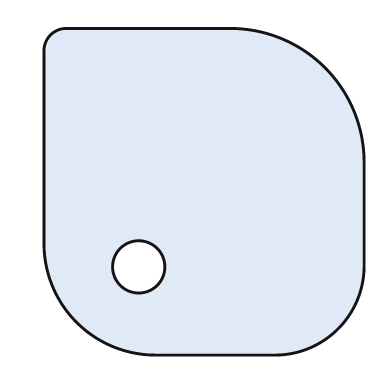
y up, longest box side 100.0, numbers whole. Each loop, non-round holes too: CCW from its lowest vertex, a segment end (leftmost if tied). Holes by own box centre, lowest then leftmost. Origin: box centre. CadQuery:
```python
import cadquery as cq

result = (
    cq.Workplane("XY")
    .moveTo(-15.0, -50.0)
    .lineTo(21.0, -50.0)
    .threePointArc((41.0, -42.0), (49.0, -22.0))
    .lineTo(49.0, 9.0)
    .threePointArc((37.0, 38.0), (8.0, 50.0))
    .lineTo(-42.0, 50.0)
    .threePointArc((-47.0, 48.0), (-49.0, 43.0))
    .lineTo(-49.0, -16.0)
    .threePointArc((-39.0, -40.0), (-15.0, -50.0))
    .close()
    .moveTo(-20.0, -23.0)
    .circle(8.0)
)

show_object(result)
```